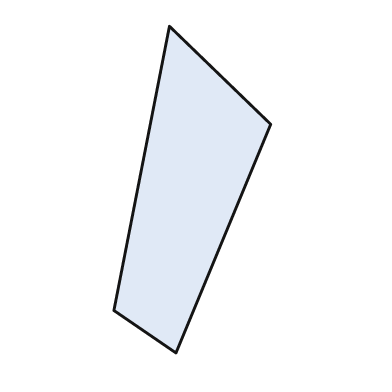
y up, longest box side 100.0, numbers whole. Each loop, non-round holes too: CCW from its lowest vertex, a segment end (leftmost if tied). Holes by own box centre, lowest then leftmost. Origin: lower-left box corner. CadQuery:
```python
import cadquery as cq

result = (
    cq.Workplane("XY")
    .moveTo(19.0, 0.0)
    .lineTo(48.0, 70.0)
    .lineTo(17.0, 100.0)
    .lineTo(0.0, 13.0)
    .close()
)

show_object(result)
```